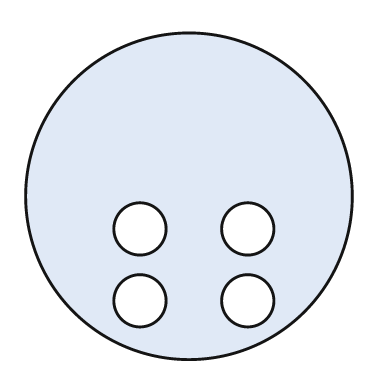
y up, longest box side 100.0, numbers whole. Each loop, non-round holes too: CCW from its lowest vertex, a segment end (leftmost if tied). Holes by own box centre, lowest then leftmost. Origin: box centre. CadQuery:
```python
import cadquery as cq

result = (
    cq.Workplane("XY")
    .moveTo(0.0, 0.0)
    .circle(50.0)
    .moveTo(-15.0, -32.0)
    .circle(8.0)
    .moveTo(18.0, -32.0)
    .circle(8.0)
    .moveTo(-15.0, -10.0)
    .circle(8.0)
    .moveTo(18.0, -10.0)
    .circle(8.0)
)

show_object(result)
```